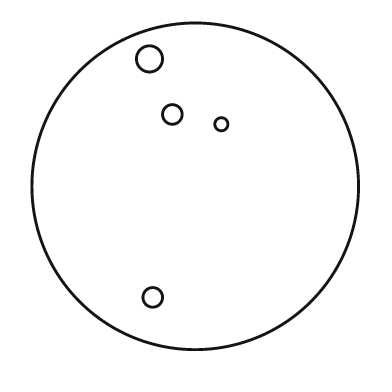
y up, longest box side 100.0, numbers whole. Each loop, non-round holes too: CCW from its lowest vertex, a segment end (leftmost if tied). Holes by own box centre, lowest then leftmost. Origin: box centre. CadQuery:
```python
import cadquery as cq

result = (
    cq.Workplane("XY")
    .moveTo(0.0, 0.0)
    .circle(50.0)
    .moveTo(-13.0, -34.0)
    .circle(3.0)
    .moveTo(8.0, 19.0)
    .circle(2.0)
    .moveTo(-7.0, 22.0)
    .circle(3.0)
    .moveTo(-14.0, 39.0)
    .circle(4.0)
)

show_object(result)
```